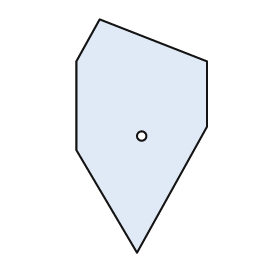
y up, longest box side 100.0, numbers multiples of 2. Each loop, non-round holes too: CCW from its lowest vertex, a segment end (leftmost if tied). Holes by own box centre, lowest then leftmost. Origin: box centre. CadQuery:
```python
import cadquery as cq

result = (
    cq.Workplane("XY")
    .moveTo(-2.0, -50.0)
    .lineTo(28.0, 4.0)
    .lineTo(28.0, 32.0)
    .lineTo(-18.0, 50.0)
    .lineTo(-28.0, 32.0)
    .lineTo(-28.0, -6.0)
    .close()
    .moveTo(0.0, 0.0)
    .circle(2.0)
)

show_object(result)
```